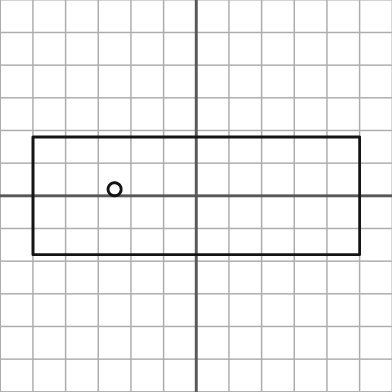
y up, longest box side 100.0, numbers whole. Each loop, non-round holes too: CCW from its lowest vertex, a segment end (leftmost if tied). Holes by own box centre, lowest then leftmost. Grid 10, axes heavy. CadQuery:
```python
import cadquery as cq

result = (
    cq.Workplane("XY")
    .moveTo(-50.0, -18.0)
    .lineTo(50.0, -18.0)
    .lineTo(50.0, 18.0)
    .lineTo(-50.0, 18.0)
    .close()
    .moveTo(-25.0, 2.0)
    .circle(2.0)
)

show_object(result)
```